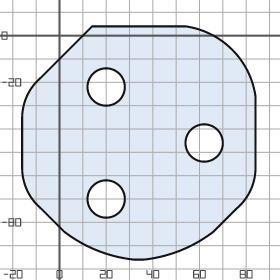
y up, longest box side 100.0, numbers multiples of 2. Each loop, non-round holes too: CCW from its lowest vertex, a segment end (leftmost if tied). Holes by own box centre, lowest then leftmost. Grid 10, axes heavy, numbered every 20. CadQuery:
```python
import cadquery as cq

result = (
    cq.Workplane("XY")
    .moveTo(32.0, -96.0)
    .lineTo(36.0, -96.0)
    .threePointArc((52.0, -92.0), (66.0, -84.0))
    .lineTo(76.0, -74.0)
    .threePointArc((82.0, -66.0), (84.0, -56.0))
    .lineTo(84.0, -26.0)
    .threePointArc((74.0, -6.0), (54.0, 4.0))
    .lineTo(14.0, 4.0)
    .lineTo(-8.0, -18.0)
    .threePointArc((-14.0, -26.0), (-16.0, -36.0))
    .lineTo(-16.0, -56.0)
    .threePointArc((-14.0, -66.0), (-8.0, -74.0))
    .lineTo(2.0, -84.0)
    .threePointArc((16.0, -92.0), (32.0, -96.0))
    .close()
    .moveTo(20.0, -70.0)
    .circle(8.0)
    .moveTo(62.0, -46.0)
    .circle(8.0)
    .moveTo(20.0, -22.0)
    .circle(8.0)
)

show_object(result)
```